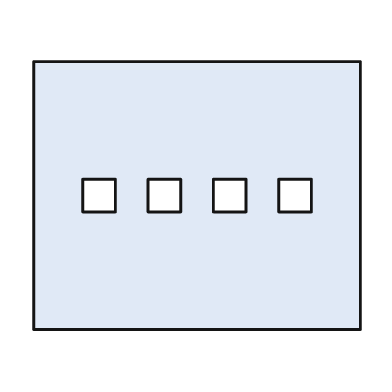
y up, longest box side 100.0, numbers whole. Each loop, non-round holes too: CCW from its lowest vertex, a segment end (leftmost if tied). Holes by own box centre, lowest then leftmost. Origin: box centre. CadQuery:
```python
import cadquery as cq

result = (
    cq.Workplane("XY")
    .moveTo(-50.0, -41.0)
    .lineTo(50.0, -41.0)
    .lineTo(50.0, 41.0)
    .lineTo(-50.0, 41.0)
    .close()
    .moveTo(-35.0, -5.0)
    .lineTo(-25.0, -5.0)
    .lineTo(-25.0, 5.0)
    .lineTo(-35.0, 5.0)
    .close()
    .moveTo(-15.0, -5.0)
    .lineTo(-5.0, -5.0)
    .lineTo(-5.0, 5.0)
    .lineTo(-15.0, 5.0)
    .close()
    .moveTo(5.0, -5.0)
    .lineTo(15.0, -5.0)
    .lineTo(15.0, 5.0)
    .lineTo(5.0, 5.0)
    .close()
    .moveTo(25.0, -5.0)
    .lineTo(35.0, -5.0)
    .lineTo(35.0, 5.0)
    .lineTo(25.0, 5.0)
    .close()
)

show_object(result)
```